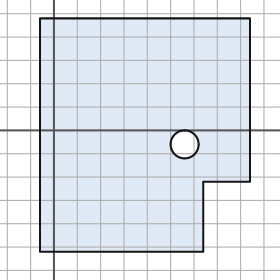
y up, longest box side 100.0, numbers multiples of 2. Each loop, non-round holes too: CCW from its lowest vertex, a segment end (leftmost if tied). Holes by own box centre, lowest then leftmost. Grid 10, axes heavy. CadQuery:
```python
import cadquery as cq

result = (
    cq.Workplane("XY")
    .moveTo(-6.0, -52.0)
    .lineTo(64.0, -52.0)
    .lineTo(64.0, -22.0)
    .lineTo(84.0, -22.0)
    .lineTo(84.0, 48.0)
    .lineTo(-6.0, 48.0)
    .close()
    .moveTo(56.0, -6.0)
    .circle(6.0)
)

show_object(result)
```